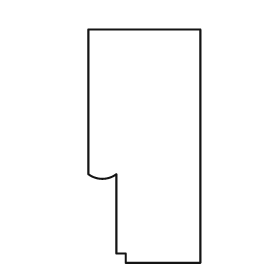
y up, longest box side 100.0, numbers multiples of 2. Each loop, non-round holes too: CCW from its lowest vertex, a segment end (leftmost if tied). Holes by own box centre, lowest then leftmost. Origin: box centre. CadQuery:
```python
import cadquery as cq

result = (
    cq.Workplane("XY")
    .moveTo(-8.0, -50.0)
    .lineTo(24.0, -50.0)
    .lineTo(24.0, 50.0)
    .lineTo(-24.0, 50.0)
    .lineTo(-24.0, -12.0)
    .threePointArc((-18.0, -14.0), (-12.0, -12.0))
    .lineTo(-12.0, -46.0)
    .lineTo(-8.0, -46.0)
    .close()
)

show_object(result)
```